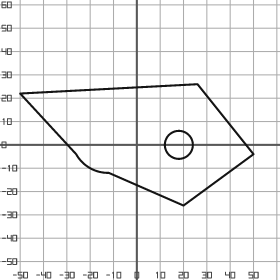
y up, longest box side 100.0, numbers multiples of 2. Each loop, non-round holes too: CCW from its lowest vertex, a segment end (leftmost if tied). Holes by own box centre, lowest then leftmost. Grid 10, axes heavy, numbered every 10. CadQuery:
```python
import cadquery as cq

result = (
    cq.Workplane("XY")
    .moveTo(20.0, -26.0)
    .lineTo(50.0, -4.0)
    .lineTo(26.0, 26.0)
    .lineTo(-50.0, 22.0)
    .lineTo(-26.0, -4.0)
    .threePointArc((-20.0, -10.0), (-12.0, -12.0))
    .close()
    .moveTo(18.0, 0.0)
    .circle(6.0)
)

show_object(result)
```